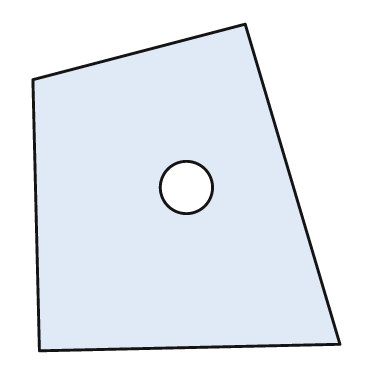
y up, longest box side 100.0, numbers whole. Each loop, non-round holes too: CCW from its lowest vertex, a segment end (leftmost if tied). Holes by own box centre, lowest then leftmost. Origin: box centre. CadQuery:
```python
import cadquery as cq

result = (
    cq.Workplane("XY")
    .moveTo(-45.0, -50.0)
    .lineTo(47.0, -48.0)
    .lineTo(18.0, 50.0)
    .lineTo(-47.0, 33.0)
    .close()
    .moveTo(0.0, 0.0)
    .circle(8.0)
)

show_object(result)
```